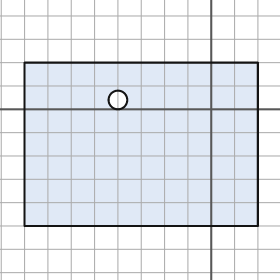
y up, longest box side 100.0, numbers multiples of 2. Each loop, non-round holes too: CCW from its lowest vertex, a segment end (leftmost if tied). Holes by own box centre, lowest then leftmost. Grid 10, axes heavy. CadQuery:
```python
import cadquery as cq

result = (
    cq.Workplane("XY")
    .moveTo(-80.0, -50.0)
    .lineTo(20.0, -50.0)
    .lineTo(20.0, 20.0)
    .lineTo(-80.0, 20.0)
    .close()
    .moveTo(-40.0, 4.0)
    .circle(4.0)
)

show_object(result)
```